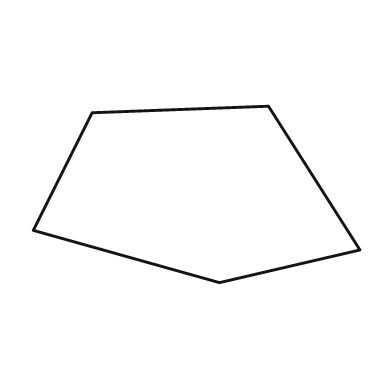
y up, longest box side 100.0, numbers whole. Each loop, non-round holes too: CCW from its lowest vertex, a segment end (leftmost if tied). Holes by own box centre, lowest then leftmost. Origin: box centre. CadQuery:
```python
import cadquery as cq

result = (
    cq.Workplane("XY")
    .moveTo(7.0, -27.0)
    .lineTo(50.0, -17.0)
    .lineTo(22.0, 27.0)
    .lineTo(-32.0, 25.0)
    .lineTo(-50.0, -11.0)
    .close()
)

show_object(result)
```